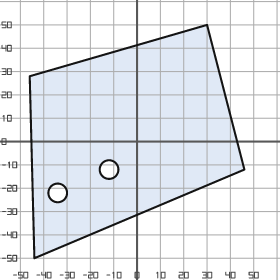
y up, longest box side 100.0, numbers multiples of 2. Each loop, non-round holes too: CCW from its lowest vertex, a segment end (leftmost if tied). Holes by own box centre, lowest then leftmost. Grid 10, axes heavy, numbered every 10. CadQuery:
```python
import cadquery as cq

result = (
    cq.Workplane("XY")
    .moveTo(-44.0, -50.0)
    .lineTo(46.0, -12.0)
    .lineTo(30.0, 50.0)
    .lineTo(-46.0, 28.0)
    .close()
    .moveTo(-34.0, -22.0)
    .circle(4.0)
    .moveTo(-12.0, -12.0)
    .circle(4.0)
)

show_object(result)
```